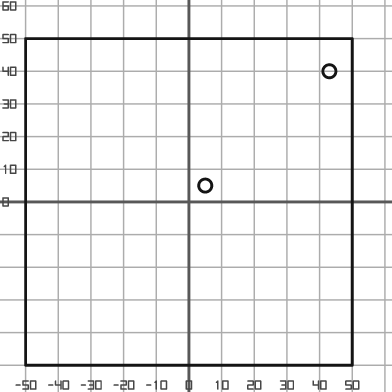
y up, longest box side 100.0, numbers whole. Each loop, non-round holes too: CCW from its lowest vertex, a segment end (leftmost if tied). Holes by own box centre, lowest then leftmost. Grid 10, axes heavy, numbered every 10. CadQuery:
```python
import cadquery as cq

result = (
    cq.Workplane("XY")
    .moveTo(-50.0, -50.0)
    .lineTo(50.0, -50.0)
    .lineTo(50.0, 50.0)
    .lineTo(-50.0, 50.0)
    .close()
    .moveTo(5.0, 5.0)
    .circle(2.0)
    .moveTo(43.0, 40.0)
    .circle(2.0)
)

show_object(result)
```